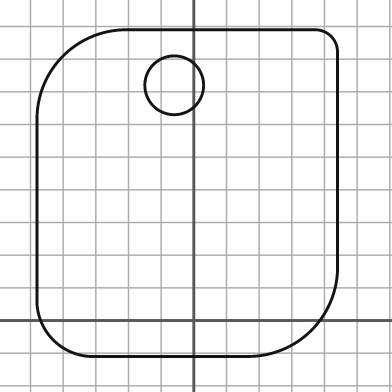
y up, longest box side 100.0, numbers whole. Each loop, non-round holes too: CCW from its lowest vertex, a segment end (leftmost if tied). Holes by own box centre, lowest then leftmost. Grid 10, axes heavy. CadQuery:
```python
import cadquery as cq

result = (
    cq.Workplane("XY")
    .moveTo(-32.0, -11.0)
    .lineTo(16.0, -11.0)
    .threePointArc((36.0, -3.0), (44.0, 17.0))
    .lineTo(44.0, 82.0)
    .threePointArc((42.0, 87.0), (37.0, 89.0))
    .lineTo(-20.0, 89.0)
    .threePointArc((-40.0, 81.0), (-48.0, 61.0))
    .lineTo(-48.0, 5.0)
    .threePointArc((-43.0, -6.0), (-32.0, -11.0))
    .close()
    .moveTo(-6.0, 72.0)
    .circle(9.0)
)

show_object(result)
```